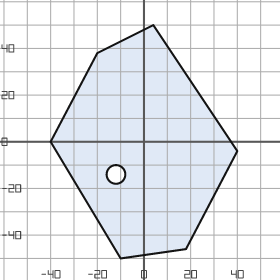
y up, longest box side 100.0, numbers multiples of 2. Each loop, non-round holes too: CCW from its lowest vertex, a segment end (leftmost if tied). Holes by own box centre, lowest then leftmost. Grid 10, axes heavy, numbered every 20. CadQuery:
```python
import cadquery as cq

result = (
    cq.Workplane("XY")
    .moveTo(-10.0, -50.0)
    .lineTo(18.0, -46.0)
    .lineTo(40.0, -4.0)
    .lineTo(4.0, 50.0)
    .lineTo(-20.0, 38.0)
    .lineTo(-40.0, 0.0)
    .close()
    .moveTo(-12.0, -14.0)
    .circle(4.0)
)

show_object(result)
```